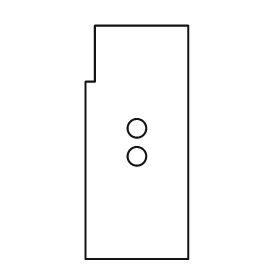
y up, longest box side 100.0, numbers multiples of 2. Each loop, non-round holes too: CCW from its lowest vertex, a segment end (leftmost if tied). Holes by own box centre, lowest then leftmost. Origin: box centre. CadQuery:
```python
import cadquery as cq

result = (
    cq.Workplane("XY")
    .moveTo(-22.0, -50.0)
    .lineTo(22.0, -50.0)
    .lineTo(22.0, 50.0)
    .lineTo(-18.0, 50.0)
    .lineTo(-18.0, 26.0)
    .lineTo(-22.0, 26.0)
    .close()
    .moveTo(0.0, -6.0)
    .circle(4.0)
    .moveTo(0.0, 6.0)
    .circle(4.0)
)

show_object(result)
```